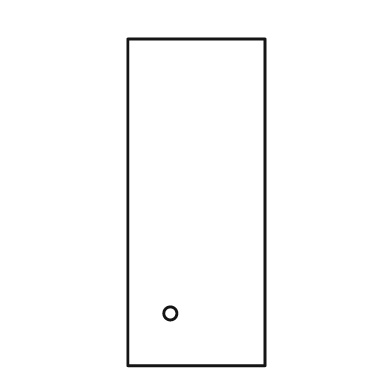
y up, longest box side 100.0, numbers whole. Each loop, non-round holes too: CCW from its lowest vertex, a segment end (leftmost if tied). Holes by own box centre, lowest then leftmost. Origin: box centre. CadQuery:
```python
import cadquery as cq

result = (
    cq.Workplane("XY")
    .moveTo(-21.0, -50.0)
    .lineTo(21.0, -50.0)
    .lineTo(21.0, 50.0)
    .lineTo(-21.0, 50.0)
    .close()
    .moveTo(-8.0, -34.0)
    .circle(2.0)
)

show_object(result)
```